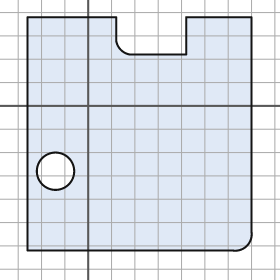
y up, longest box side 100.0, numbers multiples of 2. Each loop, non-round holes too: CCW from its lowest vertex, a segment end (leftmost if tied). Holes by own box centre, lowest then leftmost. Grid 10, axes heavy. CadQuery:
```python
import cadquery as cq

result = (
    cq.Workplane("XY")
    .moveTo(-26.0, -62.0)
    .lineTo(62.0, -62.0)
    .threePointArc((68.0, -60.0), (70.0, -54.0))
    .lineTo(70.0, 38.0)
    .lineTo(42.0, 38.0)
    .lineTo(42.0, 22.0)
    .lineTo(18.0, 22.0)
    .threePointArc((14.0, 24.0), (12.0, 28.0))
    .lineTo(12.0, 38.0)
    .lineTo(-26.0, 38.0)
    .close()
    .moveTo(-14.0, -28.0)
    .circle(8.0)
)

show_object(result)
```